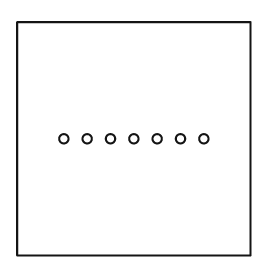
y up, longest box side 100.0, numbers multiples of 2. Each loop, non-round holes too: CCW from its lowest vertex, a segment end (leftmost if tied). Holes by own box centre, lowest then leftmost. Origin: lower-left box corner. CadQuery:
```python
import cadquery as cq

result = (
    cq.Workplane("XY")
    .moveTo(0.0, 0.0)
    .lineTo(100.0, 0.0)
    .lineTo(100.0, 100.0)
    .lineTo(0.0, 100.0)
    .close()
    .moveTo(20.0, 50.0)
    .circle(2.0)
    .moveTo(30.0, 50.0)
    .circle(2.0)
    .moveTo(40.0, 50.0)
    .circle(2.0)
    .moveTo(50.0, 50.0)
    .circle(2.0)
    .moveTo(60.0, 50.0)
    .circle(2.0)
    .moveTo(70.0, 50.0)
    .circle(2.0)
    .moveTo(80.0, 50.0)
    .circle(2.0)
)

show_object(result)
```